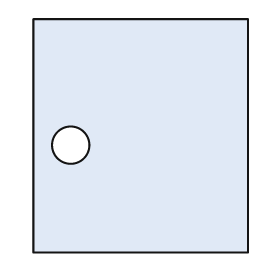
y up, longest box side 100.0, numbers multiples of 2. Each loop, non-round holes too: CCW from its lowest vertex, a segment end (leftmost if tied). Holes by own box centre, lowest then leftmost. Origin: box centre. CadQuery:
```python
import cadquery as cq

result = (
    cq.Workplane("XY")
    .moveTo(-46.0, -50.0)
    .lineTo(46.0, -50.0)
    .lineTo(46.0, 50.0)
    .lineTo(-46.0, 50.0)
    .close()
    .moveTo(-30.0, -4.0)
    .circle(8.0)
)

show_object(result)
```